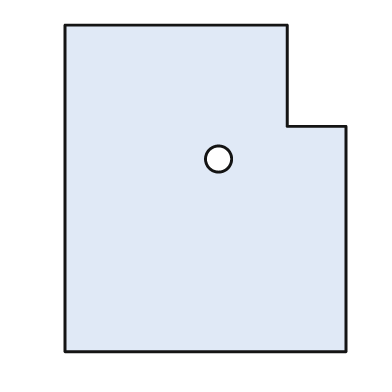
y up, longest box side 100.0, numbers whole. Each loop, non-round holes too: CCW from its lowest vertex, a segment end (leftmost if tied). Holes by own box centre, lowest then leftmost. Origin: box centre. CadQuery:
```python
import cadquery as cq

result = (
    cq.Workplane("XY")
    .moveTo(-43.0, -50.0)
    .lineTo(43.0, -50.0)
    .lineTo(43.0, 19.0)
    .lineTo(25.0, 19.0)
    .lineTo(25.0, 50.0)
    .lineTo(-43.0, 50.0)
    .close()
    .moveTo(4.0, 9.0)
    .circle(4.0)
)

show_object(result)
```